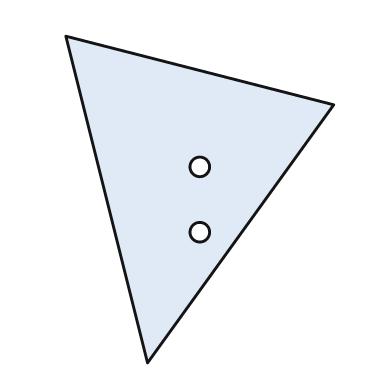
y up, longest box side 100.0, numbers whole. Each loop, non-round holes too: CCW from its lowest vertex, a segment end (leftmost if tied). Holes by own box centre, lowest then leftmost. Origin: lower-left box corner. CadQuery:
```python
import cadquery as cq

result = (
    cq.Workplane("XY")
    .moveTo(25.0, 0.0)
    .lineTo(82.0, 79.0)
    .lineTo(0.0, 100.0)
    .close()
    .moveTo(41.0, 40.0)
    .circle(3.0)
    .moveTo(41.0, 60.0)
    .circle(3.0)
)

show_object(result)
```